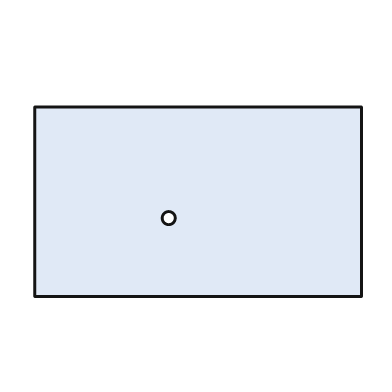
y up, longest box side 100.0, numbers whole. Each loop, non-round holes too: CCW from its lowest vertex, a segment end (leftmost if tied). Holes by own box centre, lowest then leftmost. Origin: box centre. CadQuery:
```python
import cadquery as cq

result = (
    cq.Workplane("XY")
    .moveTo(-50.0, -29.0)
    .lineTo(50.0, -29.0)
    .lineTo(50.0, 29.0)
    .lineTo(-50.0, 29.0)
    .close()
    .moveTo(-9.0, -5.0)
    .circle(2.0)
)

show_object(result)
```